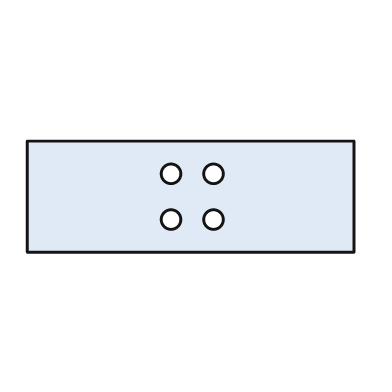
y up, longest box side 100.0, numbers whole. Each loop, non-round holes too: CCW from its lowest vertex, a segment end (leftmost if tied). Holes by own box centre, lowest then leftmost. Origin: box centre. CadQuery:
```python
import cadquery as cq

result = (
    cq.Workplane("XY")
    .moveTo(-50.0, -17.0)
    .lineTo(50.0, -17.0)
    .lineTo(50.0, 17.0)
    .lineTo(-50.0, 17.0)
    .close()
    .moveTo(-6.0, -7.0)
    .circle(3.0)
    .moveTo(7.0, -7.0)
    .circle(3.0)
    .moveTo(-6.0, 7.0)
    .circle(3.0)
    .moveTo(7.0, 7.0)
    .circle(3.0)
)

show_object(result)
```